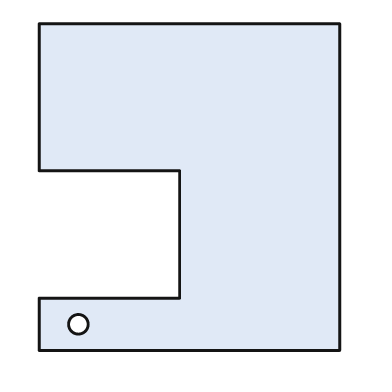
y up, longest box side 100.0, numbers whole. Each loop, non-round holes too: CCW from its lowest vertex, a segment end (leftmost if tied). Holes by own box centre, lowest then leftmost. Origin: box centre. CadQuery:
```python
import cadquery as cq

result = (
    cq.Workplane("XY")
    .moveTo(-46.0, -50.0)
    .lineTo(46.0, -50.0)
    .lineTo(46.0, 50.0)
    .lineTo(-46.0, 50.0)
    .lineTo(-46.0, 5.0)
    .lineTo(-3.0, 5.0)
    .lineTo(-3.0, -34.0)
    .lineTo(-46.0, -34.0)
    .close()
    .moveTo(-34.0, -42.0)
    .circle(3.0)
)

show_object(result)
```